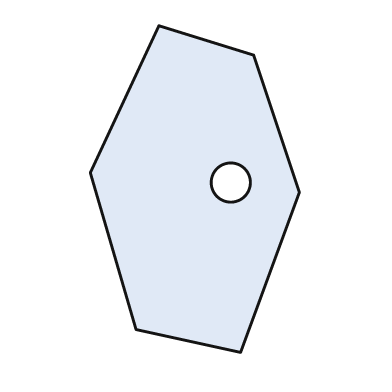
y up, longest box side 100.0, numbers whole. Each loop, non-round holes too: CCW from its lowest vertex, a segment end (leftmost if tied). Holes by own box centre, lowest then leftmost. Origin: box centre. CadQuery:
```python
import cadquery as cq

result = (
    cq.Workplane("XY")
    .moveTo(14.0, -50.0)
    .lineTo(32.0, -1.0)
    .lineTo(18.0, 41.0)
    .lineTo(-11.0, 50.0)
    .lineTo(-32.0, 5.0)
    .lineTo(-18.0, -43.0)
    .close()
    .moveTo(11.0, 2.0)
    .circle(6.0)
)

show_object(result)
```